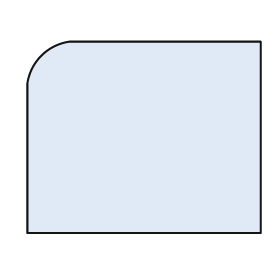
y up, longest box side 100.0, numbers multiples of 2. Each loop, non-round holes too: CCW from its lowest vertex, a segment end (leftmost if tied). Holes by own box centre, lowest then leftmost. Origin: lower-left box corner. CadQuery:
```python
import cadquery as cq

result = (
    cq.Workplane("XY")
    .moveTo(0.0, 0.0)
    .lineTo(100.0, 0.0)
    .lineTo(100.0, 82.0)
    .lineTo(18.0, 82.0)
    .threePointArc((6.0, 76.0), (0.0, 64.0))
    .close()
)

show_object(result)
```